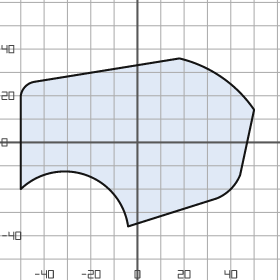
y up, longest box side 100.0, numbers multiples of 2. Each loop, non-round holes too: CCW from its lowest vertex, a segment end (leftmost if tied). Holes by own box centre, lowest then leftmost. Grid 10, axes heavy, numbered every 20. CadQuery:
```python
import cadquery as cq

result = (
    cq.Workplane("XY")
    .moveTo(-4.0, -36.0)
    .lineTo(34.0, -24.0)
    .threePointArc((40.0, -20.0), (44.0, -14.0))
    .lineTo(50.0, 14.0)
    .threePointArc((36.0, 28.0), (18.0, 36.0))
    .lineTo(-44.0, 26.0)
    .threePointArc((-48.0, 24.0), (-50.0, 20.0))
    .lineTo(-50.0, -20.0)
    .threePointArc((-22.0, -14.0), (-4.0, -36.0))
    .close()
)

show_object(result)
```